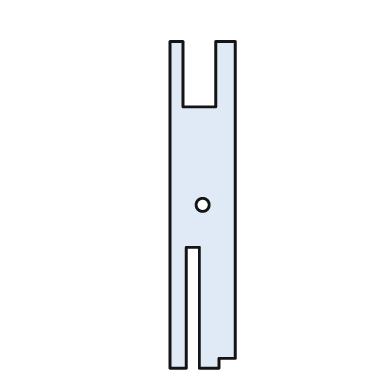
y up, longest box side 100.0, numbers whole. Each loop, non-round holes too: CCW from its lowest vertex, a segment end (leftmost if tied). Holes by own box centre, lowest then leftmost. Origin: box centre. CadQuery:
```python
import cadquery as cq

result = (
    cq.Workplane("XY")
    .moveTo(-10.0, -50.0)
    .lineTo(-5.0, -50.0)
    .lineTo(-5.0, -13.0)
    .lineTo(-1.0, -13.0)
    .lineTo(-1.0, -50.0)
    .lineTo(5.0, -50.0)
    .lineTo(5.0, -47.0)
    .lineTo(10.0, -47.0)
    .lineTo(10.0, 50.0)
    .lineTo(4.0, 50.0)
    .lineTo(4.0, 30.0)
    .lineTo(-6.0, 30.0)
    .lineTo(-6.0, 50.0)
    .lineTo(-10.0, 50.0)
    .close()
    .moveTo(0.0, 0.0)
    .circle(2.0)
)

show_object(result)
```